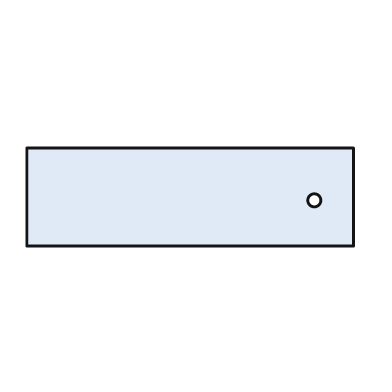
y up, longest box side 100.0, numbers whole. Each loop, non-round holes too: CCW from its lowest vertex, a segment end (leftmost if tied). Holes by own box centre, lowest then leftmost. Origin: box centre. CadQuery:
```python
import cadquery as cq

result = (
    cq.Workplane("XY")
    .moveTo(-50.0, -15.0)
    .lineTo(50.0, -15.0)
    .lineTo(50.0, 15.0)
    .lineTo(-50.0, 15.0)
    .close()
    .moveTo(38.0, -1.0)
    .circle(2.0)
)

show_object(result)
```